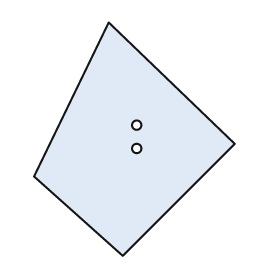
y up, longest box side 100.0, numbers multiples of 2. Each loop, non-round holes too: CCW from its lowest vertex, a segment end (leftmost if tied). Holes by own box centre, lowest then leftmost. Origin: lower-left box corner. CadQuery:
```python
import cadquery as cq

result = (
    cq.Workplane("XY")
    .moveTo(38.0, 0.0)
    .lineTo(86.0, 48.0)
    .lineTo(32.0, 100.0)
    .lineTo(0.0, 34.0)
    .close()
    .moveTo(44.0, 46.0)
    .circle(2.0)
    .moveTo(44.0, 56.0)
    .circle(2.0)
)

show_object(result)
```